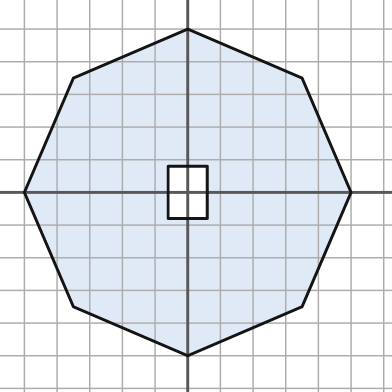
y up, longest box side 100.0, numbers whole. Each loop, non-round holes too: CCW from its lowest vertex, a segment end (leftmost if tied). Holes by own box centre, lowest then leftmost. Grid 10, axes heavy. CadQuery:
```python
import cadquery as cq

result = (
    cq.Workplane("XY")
    .moveTo(0.0, -50.0)
    .lineTo(35.0, -35.0)
    .lineTo(50.0, 0.0)
    .lineTo(35.0, 35.0)
    .lineTo(0.0, 50.0)
    .lineTo(-35.0, 35.0)
    .lineTo(-50.0, 0.0)
    .lineTo(-35.0, -35.0)
    .close()
    .moveTo(-6.0, -8.0)
    .lineTo(6.0, -8.0)
    .lineTo(6.0, 8.0)
    .lineTo(-6.0, 8.0)
    .close()
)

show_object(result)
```